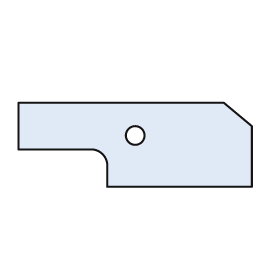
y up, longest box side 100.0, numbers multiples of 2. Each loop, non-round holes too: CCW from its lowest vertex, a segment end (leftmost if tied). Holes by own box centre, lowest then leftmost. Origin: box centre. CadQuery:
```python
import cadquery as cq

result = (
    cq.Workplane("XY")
    .moveTo(-12.0, -18.0)
    .lineTo(50.0, -18.0)
    .lineTo(50.0, 8.0)
    .lineTo(38.0, 18.0)
    .lineTo(-50.0, 18.0)
    .lineTo(-50.0, -2.0)
    .lineTo(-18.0, -2.0)
    .threePointArc((-14.0, -4.0), (-12.0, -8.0))
    .close()
    .moveTo(0.0, 4.0)
    .circle(4.0)
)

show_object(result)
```